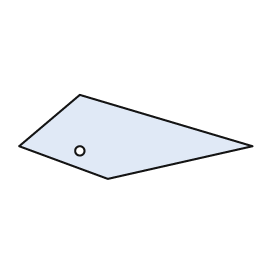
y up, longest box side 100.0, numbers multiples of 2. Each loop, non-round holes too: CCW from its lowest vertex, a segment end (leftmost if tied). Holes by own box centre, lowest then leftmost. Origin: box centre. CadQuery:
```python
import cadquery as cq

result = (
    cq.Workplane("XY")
    .moveTo(-12.0, -18.0)
    .lineTo(50.0, -4.0)
    .lineTo(-24.0, 18.0)
    .lineTo(-50.0, -4.0)
    .close()
    .moveTo(-24.0, -6.0)
    .circle(2.0)
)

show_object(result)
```